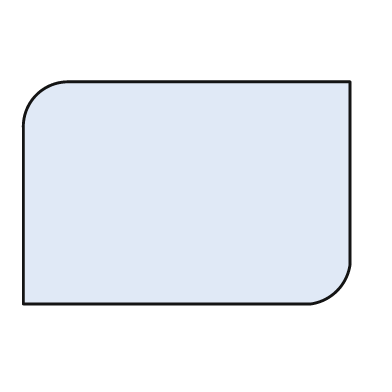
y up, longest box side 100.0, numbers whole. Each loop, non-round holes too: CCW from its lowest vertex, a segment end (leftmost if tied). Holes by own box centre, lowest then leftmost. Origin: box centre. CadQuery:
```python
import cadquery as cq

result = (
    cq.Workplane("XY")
    .moveTo(-50.0, -34.0)
    .lineTo(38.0, -34.0)
    .threePointArc((46.0, -30.0), (50.0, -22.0))
    .lineTo(50.0, 34.0)
    .lineTo(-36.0, 34.0)
    .threePointArc((-46.0, 30.0), (-50.0, 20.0))
    .close()
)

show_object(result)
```